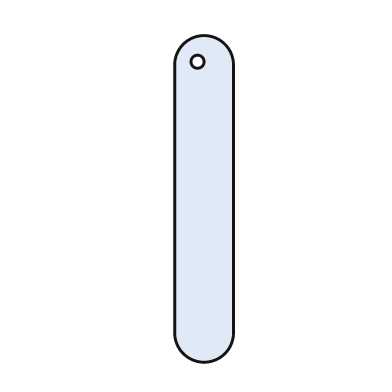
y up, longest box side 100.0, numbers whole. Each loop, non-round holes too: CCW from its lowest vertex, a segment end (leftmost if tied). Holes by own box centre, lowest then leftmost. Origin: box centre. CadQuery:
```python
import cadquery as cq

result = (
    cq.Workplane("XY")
    .moveTo(-9.0, -41.0)
    .threePointArc((0.0, -50.0), (9.0, -41.0))
    .lineTo(9.0, 41.0)
    .threePointArc((0.0, 50.0), (-9.0, 41.0))
    .close()
    .moveTo(-2.0, 42.0)
    .circle(2.0)
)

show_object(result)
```